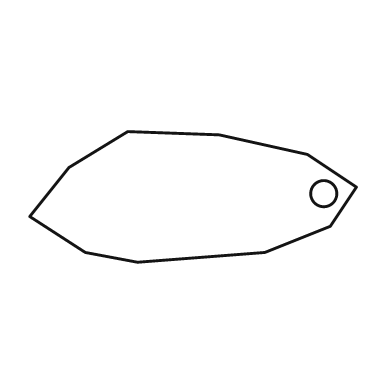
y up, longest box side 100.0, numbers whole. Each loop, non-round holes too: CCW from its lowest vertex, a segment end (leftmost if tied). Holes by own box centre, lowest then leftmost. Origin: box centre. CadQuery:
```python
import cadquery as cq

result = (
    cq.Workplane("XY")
    .moveTo(-17.0, -20.0)
    .lineTo(22.0, -17.0)
    .lineTo(42.0, -9.0)
    .lineTo(50.0, 3.0)
    .lineTo(35.0, 13.0)
    .lineTo(8.0, 19.0)
    .lineTo(-20.0, 20.0)
    .lineTo(-38.0, 9.0)
    .lineTo(-50.0, -6.0)
    .lineTo(-33.0, -17.0)
    .close()
    .moveTo(40.0, 1.0)
    .circle(4.0)
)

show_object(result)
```